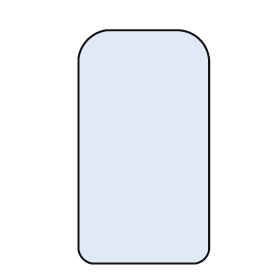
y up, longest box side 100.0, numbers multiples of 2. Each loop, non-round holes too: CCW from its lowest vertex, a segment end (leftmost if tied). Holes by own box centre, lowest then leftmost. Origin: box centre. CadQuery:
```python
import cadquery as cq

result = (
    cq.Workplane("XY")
    .moveTo(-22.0, -50.0)
    .lineTo(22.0, -50.0)
    .threePointArc((26.0, -48.0), (28.0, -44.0))
    .lineTo(28.0, 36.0)
    .threePointArc((24.0, 46.0), (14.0, 50.0))
    .lineTo(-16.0, 50.0)
    .threePointArc((-24.0, 46.0), (-28.0, 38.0))
    .lineTo(-28.0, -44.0)
    .threePointArc((-26.0, -48.0), (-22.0, -50.0))
    .close()
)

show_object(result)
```